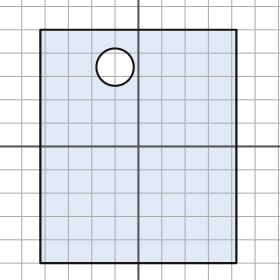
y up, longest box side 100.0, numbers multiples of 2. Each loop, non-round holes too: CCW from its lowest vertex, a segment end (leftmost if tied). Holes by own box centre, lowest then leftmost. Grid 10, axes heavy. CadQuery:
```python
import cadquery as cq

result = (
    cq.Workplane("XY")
    .moveTo(-42.0, -50.0)
    .lineTo(42.0, -50.0)
    .lineTo(42.0, 50.0)
    .lineTo(-42.0, 50.0)
    .close()
    .moveTo(-10.0, 34.0)
    .circle(8.0)
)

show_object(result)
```